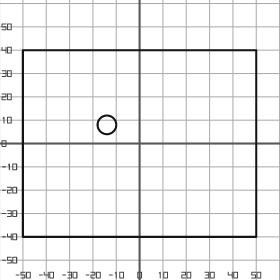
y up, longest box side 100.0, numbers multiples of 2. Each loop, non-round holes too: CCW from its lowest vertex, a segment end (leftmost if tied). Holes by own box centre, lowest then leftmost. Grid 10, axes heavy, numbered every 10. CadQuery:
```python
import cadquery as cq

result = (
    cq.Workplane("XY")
    .moveTo(-50.0, -40.0)
    .lineTo(50.0, -40.0)
    .lineTo(50.0, 40.0)
    .lineTo(-50.0, 40.0)
    .close()
    .moveTo(-14.0, 8.0)
    .circle(4.0)
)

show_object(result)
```